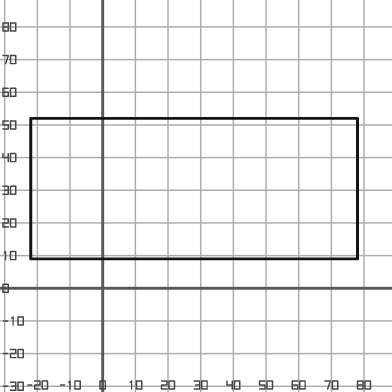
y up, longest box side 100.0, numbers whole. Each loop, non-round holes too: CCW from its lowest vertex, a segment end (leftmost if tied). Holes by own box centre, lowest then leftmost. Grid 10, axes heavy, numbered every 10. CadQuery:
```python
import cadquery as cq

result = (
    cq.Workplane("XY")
    .moveTo(-22.0, 9.0)
    .lineTo(78.0, 9.0)
    .lineTo(78.0, 52.0)
    .lineTo(-22.0, 52.0)
    .close()
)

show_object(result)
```